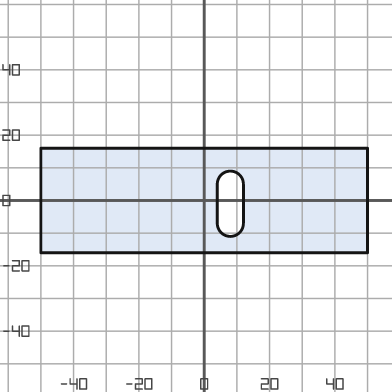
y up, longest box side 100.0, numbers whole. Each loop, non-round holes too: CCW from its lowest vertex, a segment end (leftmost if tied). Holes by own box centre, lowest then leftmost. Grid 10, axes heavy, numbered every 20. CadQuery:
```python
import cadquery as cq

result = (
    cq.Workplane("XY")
    .moveTo(-50.0, -16.0)
    .lineTo(50.0, -16.0)
    .lineTo(50.0, 16.0)
    .lineTo(-50.0, 16.0)
    .close()
    .moveTo(4.0, -7.0)
    .threePointArc((8.0, -11.0), (12.0, -7.0))
    .lineTo(12.0, 5.0)
    .threePointArc((8.0, 9.0), (4.0, 5.0))
    .close()
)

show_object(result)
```